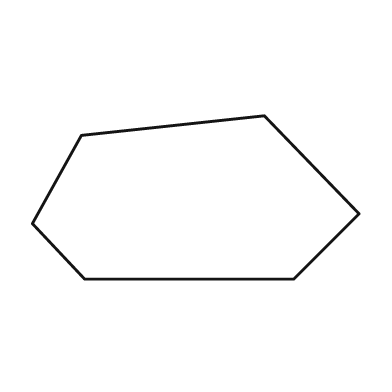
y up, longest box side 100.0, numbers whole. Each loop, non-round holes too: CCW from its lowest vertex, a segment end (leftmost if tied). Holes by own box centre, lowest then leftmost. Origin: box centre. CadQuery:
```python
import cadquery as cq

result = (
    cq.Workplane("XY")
    .moveTo(-34.0, -25.0)
    .lineTo(30.0, -25.0)
    .lineTo(50.0, -5.0)
    .lineTo(21.0, 25.0)
    .lineTo(-35.0, 19.0)
    .lineTo(-50.0, -8.0)
    .close()
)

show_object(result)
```